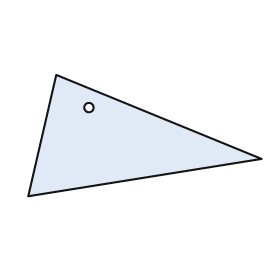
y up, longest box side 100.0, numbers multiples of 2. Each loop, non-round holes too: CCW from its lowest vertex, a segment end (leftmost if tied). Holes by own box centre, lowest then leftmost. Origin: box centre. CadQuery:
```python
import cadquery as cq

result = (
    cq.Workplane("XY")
    .moveTo(-50.0, -26.0)
    .lineTo(50.0, -10.0)
    .lineTo(-38.0, 26.0)
    .close()
    .moveTo(-24.0, 12.0)
    .circle(2.0)
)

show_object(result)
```